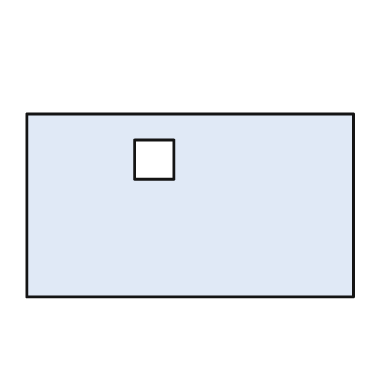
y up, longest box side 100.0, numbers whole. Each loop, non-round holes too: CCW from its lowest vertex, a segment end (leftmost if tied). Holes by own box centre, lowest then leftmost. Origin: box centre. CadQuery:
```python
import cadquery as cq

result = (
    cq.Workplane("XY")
    .moveTo(-50.0, -28.0)
    .lineTo(50.0, -28.0)
    .lineTo(50.0, 28.0)
    .lineTo(-50.0, 28.0)
    .close()
    .moveTo(-17.0, 8.0)
    .lineTo(-5.0, 8.0)
    .lineTo(-5.0, 20.0)
    .lineTo(-17.0, 20.0)
    .close()
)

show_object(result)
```